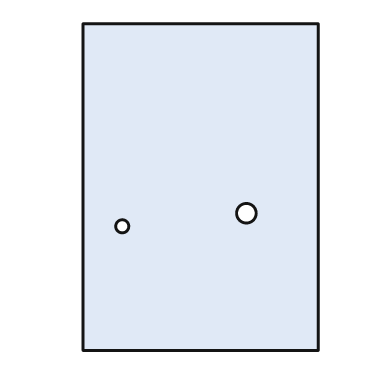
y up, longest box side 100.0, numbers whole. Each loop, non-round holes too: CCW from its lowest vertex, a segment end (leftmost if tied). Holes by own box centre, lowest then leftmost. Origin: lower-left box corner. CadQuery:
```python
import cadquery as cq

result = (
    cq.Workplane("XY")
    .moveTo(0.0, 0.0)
    .lineTo(72.0, 0.0)
    .lineTo(72.0, 100.0)
    .lineTo(0.0, 100.0)
    .close()
    .moveTo(12.0, 38.0)
    .circle(2.0)
    .moveTo(50.0, 42.0)
    .circle(3.0)
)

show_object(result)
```